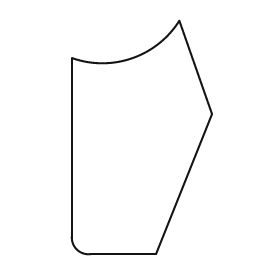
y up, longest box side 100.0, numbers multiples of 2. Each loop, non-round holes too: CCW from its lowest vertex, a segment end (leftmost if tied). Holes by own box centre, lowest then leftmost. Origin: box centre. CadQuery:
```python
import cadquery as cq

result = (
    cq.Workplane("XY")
    .moveTo(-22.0, -50.0)
    .lineTo(6.0, -50.0)
    .lineTo(30.0, 10.0)
    .lineTo(16.0, 50.0)
    .threePointArc((-4.0, 34.0), (-30.0, 34.0))
    .lineTo(-30.0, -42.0)
    .threePointArc((-28.0, -48.0), (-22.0, -50.0))
    .close()
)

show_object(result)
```